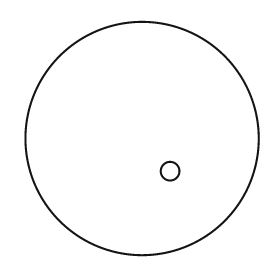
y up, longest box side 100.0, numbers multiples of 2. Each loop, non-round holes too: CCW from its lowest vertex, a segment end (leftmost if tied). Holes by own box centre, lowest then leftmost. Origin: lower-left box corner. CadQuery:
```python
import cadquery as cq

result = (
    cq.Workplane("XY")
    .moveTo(50.0, 50.0)
    .circle(50.0)
    .moveTo(62.0, 36.0)
    .circle(4.0)
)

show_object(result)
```